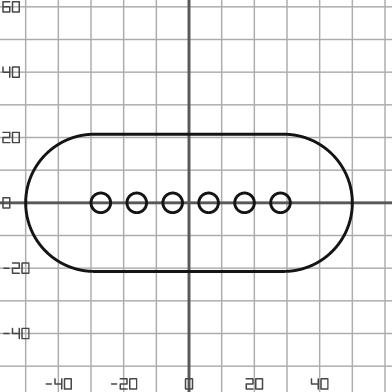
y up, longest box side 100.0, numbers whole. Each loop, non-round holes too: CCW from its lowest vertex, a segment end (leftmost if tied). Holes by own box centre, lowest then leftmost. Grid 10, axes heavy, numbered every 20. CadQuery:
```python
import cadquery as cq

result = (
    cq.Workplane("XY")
    .moveTo(-29.0, -21.0)
    .lineTo(29.0, -21.0)
    .threePointArc((50.0, 0.0), (29.0, 21.0))
    .lineTo(-29.0, 21.0)
    .threePointArc((-50.0, 0.0), (-29.0, -21.0))
    .close()
    .moveTo(-27.0, 0.0)
    .circle(3.0)
    .moveTo(-16.0, 0.0)
    .circle(3.0)
    .moveTo(-5.0, 0.0)
    .circle(3.0)
    .moveTo(6.0, 0.0)
    .circle(3.0)
    .moveTo(17.0, 0.0)
    .circle(3.0)
    .moveTo(28.0, 0.0)
    .circle(3.0)
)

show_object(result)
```